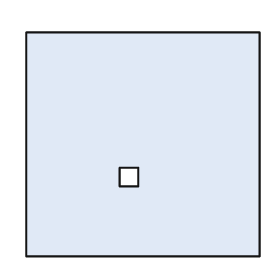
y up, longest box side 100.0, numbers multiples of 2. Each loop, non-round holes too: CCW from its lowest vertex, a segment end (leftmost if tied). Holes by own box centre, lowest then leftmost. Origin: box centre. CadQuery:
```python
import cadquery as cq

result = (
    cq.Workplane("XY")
    .moveTo(-50.0, -48.0)
    .lineTo(50.0, -48.0)
    .lineTo(50.0, 48.0)
    .lineTo(-50.0, 48.0)
    .close()
    .moveTo(-10.0, -18.0)
    .lineTo(-2.0, -18.0)
    .lineTo(-2.0, -10.0)
    .lineTo(-10.0, -10.0)
    .close()
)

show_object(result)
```